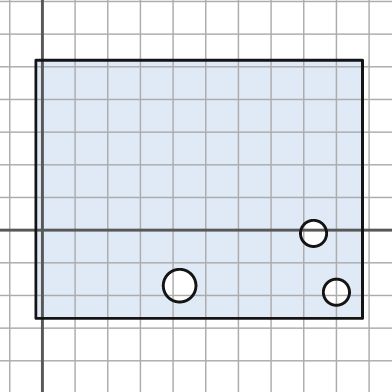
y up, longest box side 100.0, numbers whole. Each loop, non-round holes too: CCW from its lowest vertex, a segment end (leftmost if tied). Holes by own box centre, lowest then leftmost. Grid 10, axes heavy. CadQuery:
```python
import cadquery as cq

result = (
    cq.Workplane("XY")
    .moveTo(-2.0, -27.0)
    .lineTo(98.0, -27.0)
    .lineTo(98.0, 52.0)
    .lineTo(-2.0, 52.0)
    .close()
    .moveTo(90.0, -19.0)
    .circle(4.0)
    .moveTo(42.0, -17.0)
    .circle(5.0)
    .moveTo(83.0, -1.0)
    .circle(4.0)
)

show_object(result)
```